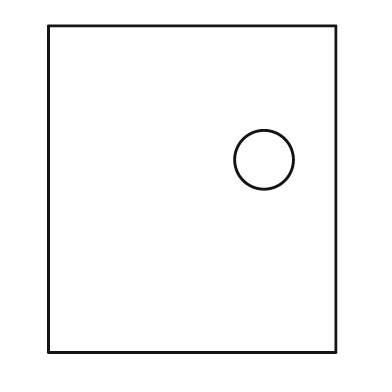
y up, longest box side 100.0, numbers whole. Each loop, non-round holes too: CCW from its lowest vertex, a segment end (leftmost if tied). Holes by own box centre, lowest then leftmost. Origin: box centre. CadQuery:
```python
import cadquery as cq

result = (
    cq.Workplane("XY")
    .moveTo(-44.0, -50.0)
    .lineTo(44.0, -50.0)
    .lineTo(44.0, 50.0)
    .lineTo(-44.0, 50.0)
    .close()
    .moveTo(22.0, 9.0)
    .circle(9.0)
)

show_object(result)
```